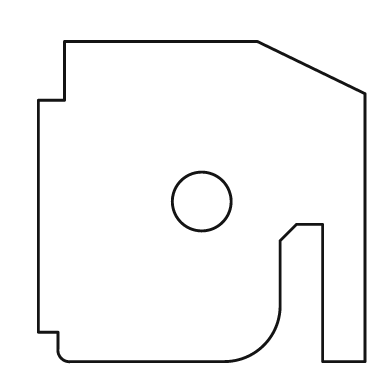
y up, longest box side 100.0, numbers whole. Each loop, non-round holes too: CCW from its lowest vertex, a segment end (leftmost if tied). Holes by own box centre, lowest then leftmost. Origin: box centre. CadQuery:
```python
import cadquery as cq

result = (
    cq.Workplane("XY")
    .moveTo(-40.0, -49.0)
    .lineTo(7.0, -49.0)
    .threePointArc((19.0, -44.0), (24.0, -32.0))
    .lineTo(24.0, -12.0)
    .lineTo(29.0, -7.0)
    .lineTo(37.0, -7.0)
    .lineTo(37.0, -49.0)
    .lineTo(50.0, -49.0)
    .lineTo(50.0, 33.0)
    .lineTo(17.0, 49.0)
    .lineTo(-42.0, 49.0)
    .lineTo(-42.0, 31.0)
    .lineTo(-50.0, 31.0)
    .lineTo(-50.0, -40.0)
    .lineTo(-44.0, -40.0)
    .lineTo(-44.0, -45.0)
    .threePointArc((-43.0, -48.0), (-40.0, -49.0))
    .close()
    .moveTo(0.0, 0.0)
    .circle(9.0)
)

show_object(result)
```